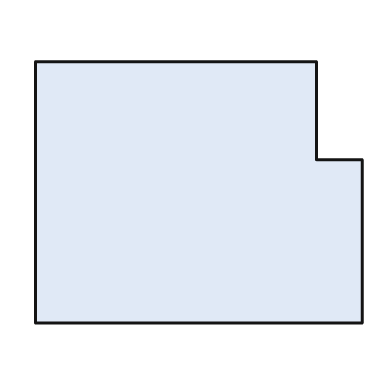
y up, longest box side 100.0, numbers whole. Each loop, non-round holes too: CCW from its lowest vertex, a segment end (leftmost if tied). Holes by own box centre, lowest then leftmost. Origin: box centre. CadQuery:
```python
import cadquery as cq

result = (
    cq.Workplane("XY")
    .moveTo(-50.0, -40.0)
    .lineTo(50.0, -40.0)
    .lineTo(50.0, 10.0)
    .lineTo(36.0, 10.0)
    .lineTo(36.0, 40.0)
    .lineTo(-50.0, 40.0)
    .close()
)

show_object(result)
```